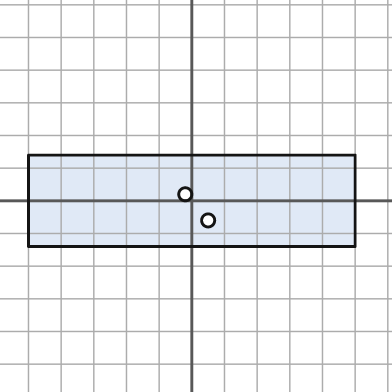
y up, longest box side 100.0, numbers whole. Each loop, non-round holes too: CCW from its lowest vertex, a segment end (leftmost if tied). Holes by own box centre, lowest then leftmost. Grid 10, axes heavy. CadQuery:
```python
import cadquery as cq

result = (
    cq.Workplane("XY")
    .moveTo(-50.0, -14.0)
    .lineTo(50.0, -14.0)
    .lineTo(50.0, 14.0)
    .lineTo(-50.0, 14.0)
    .close()
    .moveTo(5.0, -6.0)
    .circle(2.0)
    .moveTo(-2.0, 2.0)
    .circle(2.0)
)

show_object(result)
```